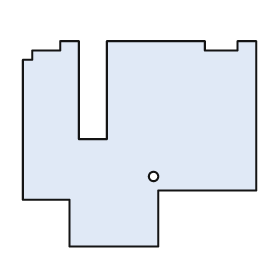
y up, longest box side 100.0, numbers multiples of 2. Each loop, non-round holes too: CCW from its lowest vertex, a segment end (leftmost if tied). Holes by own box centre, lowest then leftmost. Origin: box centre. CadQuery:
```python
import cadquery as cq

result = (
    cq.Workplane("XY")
    .moveTo(-30.0, -44.0)
    .lineTo(8.0, -44.0)
    .lineTo(8.0, -20.0)
    .lineTo(50.0, -20.0)
    .lineTo(50.0, 44.0)
    .lineTo(42.0, 44.0)
    .lineTo(42.0, 40.0)
    .lineTo(28.0, 40.0)
    .lineTo(28.0, 44.0)
    .lineTo(-14.0, 44.0)
    .lineTo(-14.0, 2.0)
    .lineTo(-26.0, 2.0)
    .lineTo(-26.0, 44.0)
    .lineTo(-34.0, 44.0)
    .lineTo(-34.0, 40.0)
    .lineTo(-46.0, 40.0)
    .lineTo(-46.0, 36.0)
    .lineTo(-50.0, 36.0)
    .lineTo(-50.0, -24.0)
    .lineTo(-30.0, -24.0)
    .close()
    .moveTo(6.0, -14.0)
    .circle(2.0)
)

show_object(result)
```